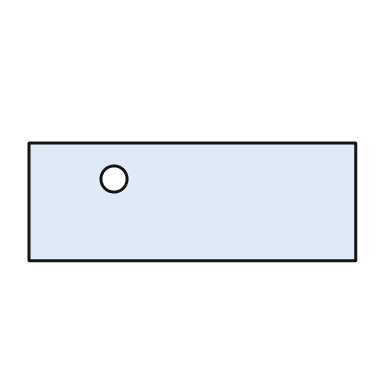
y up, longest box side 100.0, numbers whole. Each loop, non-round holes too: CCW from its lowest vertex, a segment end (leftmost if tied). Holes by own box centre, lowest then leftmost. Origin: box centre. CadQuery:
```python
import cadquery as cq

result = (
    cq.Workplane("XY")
    .moveTo(-50.0, -18.0)
    .lineTo(50.0, -18.0)
    .lineTo(50.0, 18.0)
    .lineTo(-50.0, 18.0)
    .close()
    .moveTo(-24.0, 7.0)
    .circle(4.0)
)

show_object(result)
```